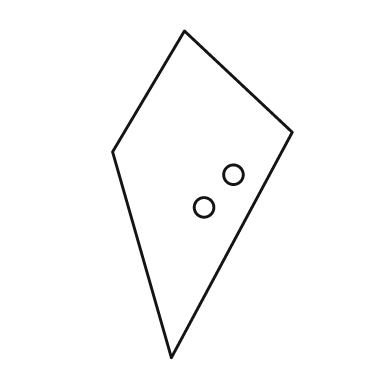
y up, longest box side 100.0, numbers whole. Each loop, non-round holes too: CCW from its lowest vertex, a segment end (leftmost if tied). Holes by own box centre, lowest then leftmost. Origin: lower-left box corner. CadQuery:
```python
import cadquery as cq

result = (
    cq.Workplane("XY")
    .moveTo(18.0, 0.0)
    .lineTo(55.0, 69.0)
    .lineTo(22.0, 100.0)
    .lineTo(0.0, 63.0)
    .close()
    .moveTo(28.0, 46.0)
    .circle(3.0)
    .moveTo(37.0, 56.0)
    .circle(3.0)
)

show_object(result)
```